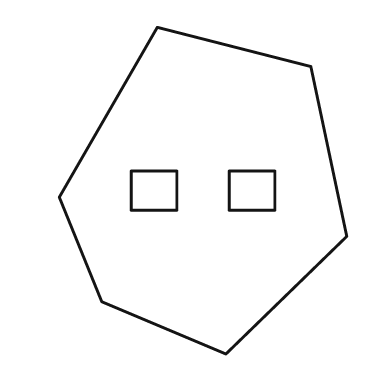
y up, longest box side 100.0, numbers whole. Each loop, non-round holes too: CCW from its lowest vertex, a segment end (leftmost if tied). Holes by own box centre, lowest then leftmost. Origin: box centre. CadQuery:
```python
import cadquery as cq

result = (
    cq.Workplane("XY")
    .moveTo(7.0, -50.0)
    .lineTo(44.0, -14.0)
    .lineTo(33.0, 38.0)
    .lineTo(-14.0, 50.0)
    .lineTo(-44.0, -2.0)
    .lineTo(-31.0, -34.0)
    .close()
    .moveTo(-22.0, -6.0)
    .lineTo(-8.0, -6.0)
    .lineTo(-8.0, 6.0)
    .lineTo(-22.0, 6.0)
    .close()
    .moveTo(8.0, -6.0)
    .lineTo(22.0, -6.0)
    .lineTo(22.0, 6.0)
    .lineTo(8.0, 6.0)
    .close()
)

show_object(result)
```